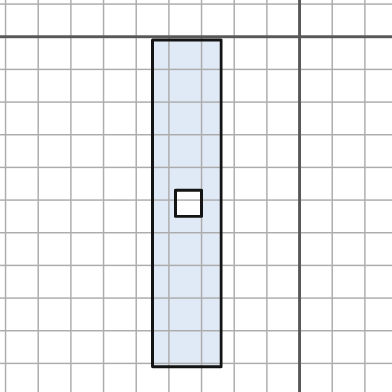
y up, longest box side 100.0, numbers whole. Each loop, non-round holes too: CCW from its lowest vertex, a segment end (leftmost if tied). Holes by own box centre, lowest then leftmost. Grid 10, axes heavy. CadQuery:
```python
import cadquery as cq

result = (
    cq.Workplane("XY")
    .moveTo(-45.0, -101.0)
    .lineTo(-24.0, -101.0)
    .lineTo(-24.0, -1.0)
    .lineTo(-45.0, -1.0)
    .close()
    .moveTo(-38.0, -55.0)
    .lineTo(-30.0, -55.0)
    .lineTo(-30.0, -47.0)
    .lineTo(-38.0, -47.0)
    .close()
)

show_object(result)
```